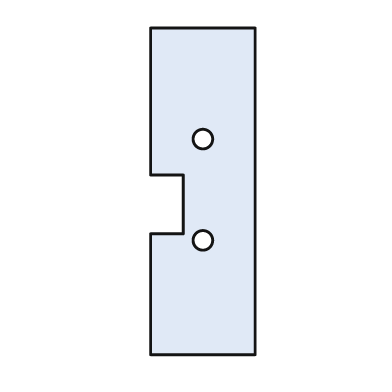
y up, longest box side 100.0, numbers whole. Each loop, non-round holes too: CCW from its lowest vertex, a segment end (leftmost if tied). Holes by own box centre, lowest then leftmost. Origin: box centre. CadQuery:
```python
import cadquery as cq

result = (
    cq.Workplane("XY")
    .moveTo(-16.0, -50.0)
    .lineTo(16.0, -50.0)
    .lineTo(16.0, 50.0)
    .lineTo(-16.0, 50.0)
    .lineTo(-16.0, 5.0)
    .lineTo(-6.0, 5.0)
    .lineTo(-6.0, -13.0)
    .lineTo(-16.0, -13.0)
    .close()
    .moveTo(0.0, -15.0)
    .circle(3.0)
    .moveTo(0.0, 16.0)
    .circle(3.0)
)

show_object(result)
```